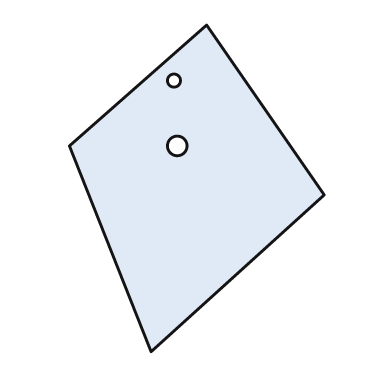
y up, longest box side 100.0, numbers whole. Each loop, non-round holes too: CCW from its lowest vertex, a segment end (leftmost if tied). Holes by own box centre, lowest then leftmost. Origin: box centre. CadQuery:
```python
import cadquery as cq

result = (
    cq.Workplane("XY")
    .moveTo(-14.0, -50.0)
    .lineTo(39.0, -2.0)
    .lineTo(3.0, 50.0)
    .lineTo(-39.0, 13.0)
    .close()
    .moveTo(-6.0, 13.0)
    .circle(3.0)
    .moveTo(-7.0, 33.0)
    .circle(2.0)
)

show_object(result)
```